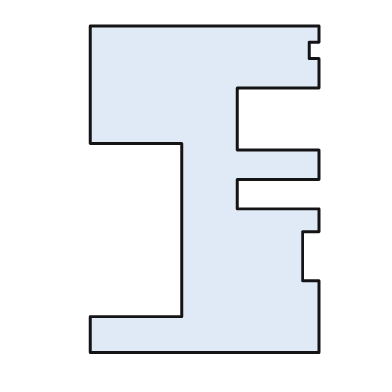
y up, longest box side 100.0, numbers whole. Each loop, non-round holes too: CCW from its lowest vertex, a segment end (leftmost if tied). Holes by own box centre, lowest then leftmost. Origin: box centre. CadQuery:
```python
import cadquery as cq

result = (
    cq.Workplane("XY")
    .moveTo(-35.0, -50.0)
    .lineTo(35.0, -50.0)
    .lineTo(35.0, -28.0)
    .lineTo(30.0, -28.0)
    .lineTo(30.0, -13.0)
    .lineTo(35.0, -13.0)
    .lineTo(35.0, -6.0)
    .lineTo(10.0, -6.0)
    .lineTo(10.0, 3.0)
    .lineTo(35.0, 3.0)
    .lineTo(35.0, 12.0)
    .lineTo(10.0, 12.0)
    .lineTo(10.0, 31.0)
    .lineTo(35.0, 31.0)
    .lineTo(35.0, 40.0)
    .lineTo(32.0, 40.0)
    .lineTo(32.0, 45.0)
    .lineTo(35.0, 45.0)
    .lineTo(35.0, 50.0)
    .lineTo(-35.0, 50.0)
    .lineTo(-35.0, 14.0)
    .lineTo(-7.0, 14.0)
    .lineTo(-7.0, -39.0)
    .lineTo(-35.0, -39.0)
    .close()
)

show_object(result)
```